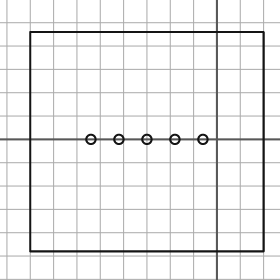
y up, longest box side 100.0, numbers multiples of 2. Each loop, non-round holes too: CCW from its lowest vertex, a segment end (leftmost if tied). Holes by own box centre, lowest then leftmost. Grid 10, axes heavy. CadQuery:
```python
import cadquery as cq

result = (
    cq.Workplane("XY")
    .moveTo(-80.0, -48.0)
    .lineTo(20.0, -48.0)
    .lineTo(20.0, 46.0)
    .lineTo(-80.0, 46.0)
    .close()
    .moveTo(-54.0, 0.0)
    .circle(2.0)
    .moveTo(-42.0, 0.0)
    .circle(2.0)
    .moveTo(-30.0, 0.0)
    .circle(2.0)
    .moveTo(-18.0, 0.0)
    .circle(2.0)
    .moveTo(-6.0, 0.0)
    .circle(2.0)
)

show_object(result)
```